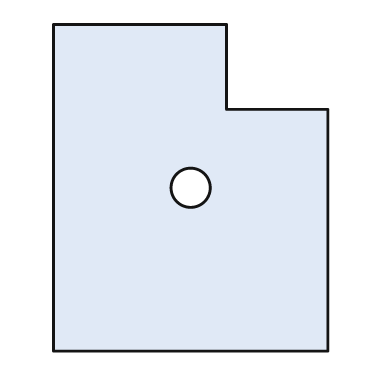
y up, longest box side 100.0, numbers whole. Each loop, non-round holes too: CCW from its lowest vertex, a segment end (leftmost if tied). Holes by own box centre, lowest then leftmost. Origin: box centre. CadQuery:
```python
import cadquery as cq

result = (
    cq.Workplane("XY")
    .moveTo(-42.0, -50.0)
    .lineTo(42.0, -50.0)
    .lineTo(42.0, 24.0)
    .lineTo(11.0, 24.0)
    .lineTo(11.0, 50.0)
    .lineTo(-42.0, 50.0)
    .close()
    .moveTo(0.0, 0.0)
    .circle(6.0)
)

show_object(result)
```